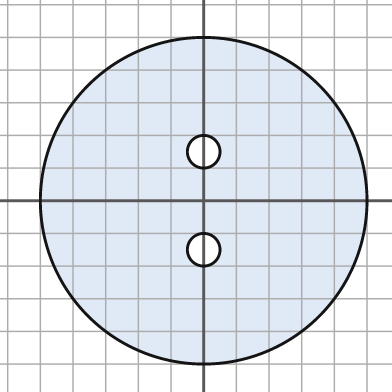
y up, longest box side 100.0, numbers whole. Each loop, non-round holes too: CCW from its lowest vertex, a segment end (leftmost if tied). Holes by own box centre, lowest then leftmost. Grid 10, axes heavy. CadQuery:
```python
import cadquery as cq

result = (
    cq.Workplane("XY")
    .moveTo(0.0, 0.0)
    .circle(50.0)
    .moveTo(0.0, -15.0)
    .circle(5.0)
    .moveTo(0.0, 15.0)
    .circle(5.0)
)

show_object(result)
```